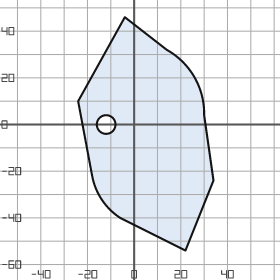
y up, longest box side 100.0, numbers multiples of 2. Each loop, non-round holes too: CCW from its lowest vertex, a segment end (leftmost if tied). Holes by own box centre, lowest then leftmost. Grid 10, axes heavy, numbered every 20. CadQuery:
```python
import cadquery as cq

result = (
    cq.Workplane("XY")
    .moveTo(22.0, -54.0)
    .lineTo(34.0, -24.0)
    .lineTo(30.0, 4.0)
    .threePointArc((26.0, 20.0), (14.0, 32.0))
    .lineTo(-4.0, 46.0)
    .lineTo(-24.0, 10.0)
    .lineTo(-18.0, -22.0)
    .threePointArc((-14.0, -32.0), (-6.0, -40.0))
    .close()
    .moveTo(-12.0, 0.0)
    .circle(4.0)
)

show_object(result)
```